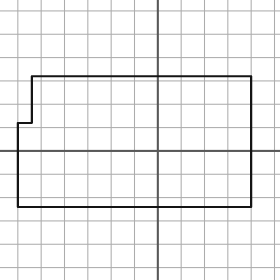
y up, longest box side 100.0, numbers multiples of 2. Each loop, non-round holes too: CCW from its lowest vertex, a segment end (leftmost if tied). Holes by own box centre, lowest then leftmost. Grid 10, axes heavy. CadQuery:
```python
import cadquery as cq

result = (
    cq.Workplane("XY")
    .moveTo(-60.0, -24.0)
    .lineTo(40.0, -24.0)
    .lineTo(40.0, 32.0)
    .lineTo(-54.0, 32.0)
    .lineTo(-54.0, 12.0)
    .lineTo(-60.0, 12.0)
    .close()
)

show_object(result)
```